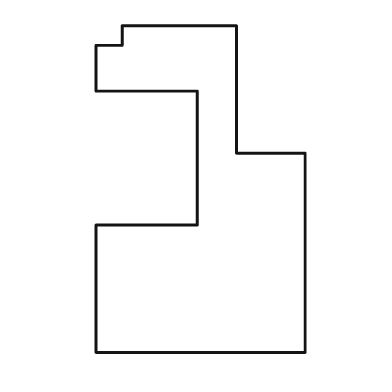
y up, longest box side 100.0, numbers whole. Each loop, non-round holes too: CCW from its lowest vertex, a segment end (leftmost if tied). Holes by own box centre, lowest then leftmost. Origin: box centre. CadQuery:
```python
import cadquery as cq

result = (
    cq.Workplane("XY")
    .moveTo(-32.0, -50.0)
    .lineTo(32.0, -50.0)
    .lineTo(32.0, 11.0)
    .lineTo(11.0, 11.0)
    .lineTo(11.0, 50.0)
    .lineTo(-24.0, 50.0)
    .lineTo(-24.0, 44.0)
    .lineTo(-32.0, 44.0)
    .lineTo(-32.0, 30.0)
    .lineTo(-1.0, 30.0)
    .lineTo(-1.0, -11.0)
    .lineTo(-32.0, -11.0)
    .close()
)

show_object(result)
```